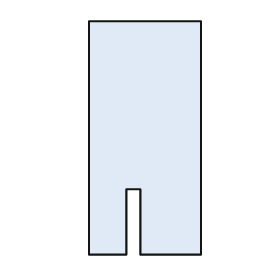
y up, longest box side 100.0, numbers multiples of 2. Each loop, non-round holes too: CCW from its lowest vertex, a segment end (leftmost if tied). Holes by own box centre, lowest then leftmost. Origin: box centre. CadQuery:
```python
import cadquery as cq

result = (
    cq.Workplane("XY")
    .moveTo(-24.0, -50.0)
    .lineTo(-8.0, -50.0)
    .lineTo(-8.0, -22.0)
    .lineTo(-2.0, -22.0)
    .lineTo(-2.0, -50.0)
    .lineTo(24.0, -50.0)
    .lineTo(24.0, 50.0)
    .lineTo(-24.0, 50.0)
    .close()
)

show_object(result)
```